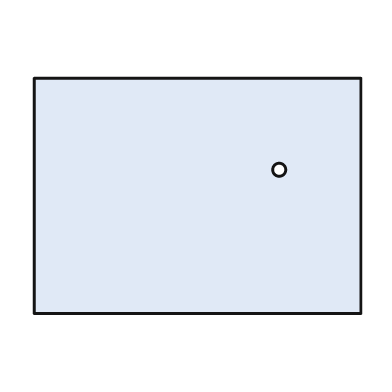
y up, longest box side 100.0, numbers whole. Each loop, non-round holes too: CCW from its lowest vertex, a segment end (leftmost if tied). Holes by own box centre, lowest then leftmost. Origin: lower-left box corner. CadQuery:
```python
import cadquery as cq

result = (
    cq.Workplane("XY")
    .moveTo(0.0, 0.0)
    .lineTo(100.0, 0.0)
    .lineTo(100.0, 72.0)
    .lineTo(0.0, 72.0)
    .close()
    .moveTo(75.0, 44.0)
    .circle(2.0)
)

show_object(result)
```